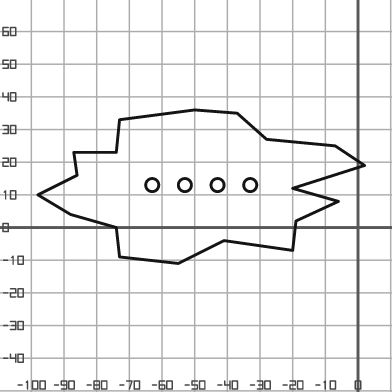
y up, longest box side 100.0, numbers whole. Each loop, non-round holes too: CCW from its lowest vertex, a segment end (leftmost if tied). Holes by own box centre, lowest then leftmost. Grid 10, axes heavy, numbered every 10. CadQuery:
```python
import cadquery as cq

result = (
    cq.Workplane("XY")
    .moveTo(-55.0, -11.0)
    .lineTo(-41.0, -4.0)
    .lineTo(-20.0, -7.0)
    .lineTo(-19.0, 2.0)
    .lineTo(-6.0, 8.0)
    .lineTo(-20.0, 12.0)
    .lineTo(2.0, 19.0)
    .lineTo(-7.0, 25.0)
    .lineTo(-28.0, 27.0)
    .lineTo(-37.0, 35.0)
    .lineTo(-50.0, 36.0)
    .lineTo(-73.0, 33.0)
    .lineTo(-74.0, 23.0)
    .lineTo(-87.0, 23.0)
    .lineTo(-86.0, 16.0)
    .lineTo(-98.0, 10.0)
    .lineTo(-88.0, 4.0)
    .lineTo(-74.0, 0.0)
    .lineTo(-73.0, -9.0)
    .close()
    .moveTo(-63.0, 13.0)
    .circle(2.0)
    .moveTo(-53.0, 13.0)
    .circle(2.0)
    .moveTo(-43.0, 13.0)
    .circle(2.0)
    .moveTo(-33.0, 13.0)
    .circle(2.0)
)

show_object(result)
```